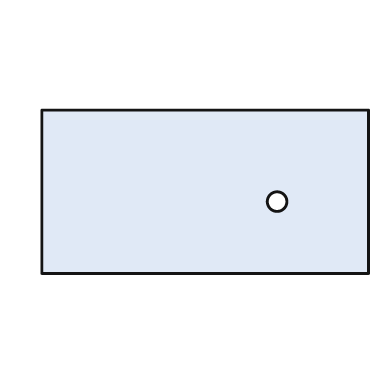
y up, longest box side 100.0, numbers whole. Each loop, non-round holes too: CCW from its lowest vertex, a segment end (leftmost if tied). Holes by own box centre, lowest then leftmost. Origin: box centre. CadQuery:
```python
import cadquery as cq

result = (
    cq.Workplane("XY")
    .moveTo(-50.0, -25.0)
    .lineTo(50.0, -25.0)
    .lineTo(50.0, 25.0)
    .lineTo(-50.0, 25.0)
    .close()
    .moveTo(22.0, -3.0)
    .circle(3.0)
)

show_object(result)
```